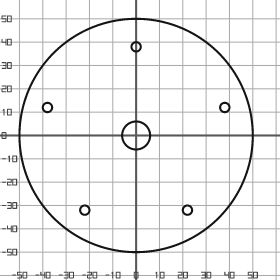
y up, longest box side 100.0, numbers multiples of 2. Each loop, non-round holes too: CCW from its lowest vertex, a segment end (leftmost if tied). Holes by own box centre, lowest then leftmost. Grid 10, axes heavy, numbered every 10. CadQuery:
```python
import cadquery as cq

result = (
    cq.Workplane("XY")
    .moveTo(0.0, 0.0)
    .circle(50.0)
    .moveTo(-22.0, -32.0)
    .circle(2.0)
    .moveTo(22.0, -32.0)
    .circle(2.0)
    .moveTo(0.0, 0.0)
    .circle(6.0)
    .moveTo(-38.0, 12.0)
    .circle(2.0)
    .moveTo(38.0, 12.0)
    .circle(2.0)
    .moveTo(0.0, 38.0)
    .circle(2.0)
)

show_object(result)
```